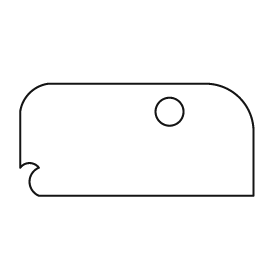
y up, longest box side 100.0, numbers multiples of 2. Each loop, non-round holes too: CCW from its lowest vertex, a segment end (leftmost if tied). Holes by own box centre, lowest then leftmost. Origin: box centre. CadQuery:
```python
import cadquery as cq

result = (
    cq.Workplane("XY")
    .moveTo(-42.0, -24.0)
    .lineTo(50.0, -24.0)
    .lineTo(50.0, 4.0)
    .threePointArc((44.0, 18.0), (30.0, 24.0))
    .lineTo(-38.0, 24.0)
    .threePointArc((-46.0, 20.0), (-50.0, 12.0))
    .lineTo(-50.0, -12.0)
    .threePointArc((-46.0, -10.0), (-42.0, -12.0))
    .threePointArc((-46.0, -18.0), (-42.0, -24.0))
    .close()
    .moveTo(14.0, 12.0)
    .circle(6.0)
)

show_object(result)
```